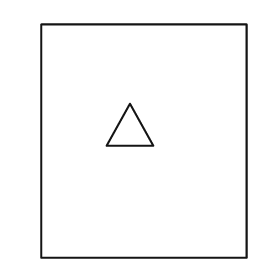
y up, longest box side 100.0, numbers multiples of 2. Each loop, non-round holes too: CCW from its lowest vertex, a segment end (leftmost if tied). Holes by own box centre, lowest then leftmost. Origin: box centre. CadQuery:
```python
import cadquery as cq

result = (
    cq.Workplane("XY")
    .moveTo(-44.0, -50.0)
    .lineTo(44.0, -50.0)
    .lineTo(44.0, 50.0)
    .lineTo(-44.0, 50.0)
    .close()
    .moveTo(-16.0, -2.0)
    .lineTo(4.0, -2.0)
    .lineTo(-6.0, 16.0)
    .close()
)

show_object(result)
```